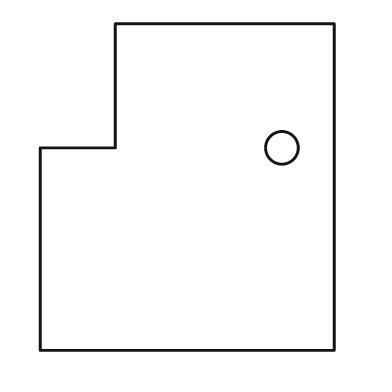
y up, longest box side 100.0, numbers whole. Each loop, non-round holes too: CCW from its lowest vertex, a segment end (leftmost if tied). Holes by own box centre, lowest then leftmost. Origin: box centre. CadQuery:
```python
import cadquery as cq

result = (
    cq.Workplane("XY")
    .moveTo(-45.0, -50.0)
    .lineTo(45.0, -50.0)
    .lineTo(45.0, 50.0)
    .lineTo(-22.0, 50.0)
    .lineTo(-22.0, 12.0)
    .lineTo(-45.0, 12.0)
    .close()
    .moveTo(29.0, 12.0)
    .circle(5.0)
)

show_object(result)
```